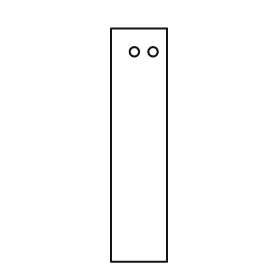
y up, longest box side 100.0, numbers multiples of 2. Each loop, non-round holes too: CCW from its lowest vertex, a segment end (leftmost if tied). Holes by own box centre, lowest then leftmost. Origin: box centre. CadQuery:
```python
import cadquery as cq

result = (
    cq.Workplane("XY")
    .moveTo(-12.0, -50.0)
    .lineTo(12.0, -50.0)
    .lineTo(12.0, 50.0)
    .lineTo(-12.0, 50.0)
    .close()
    .moveTo(-2.0, 40.0)
    .circle(2.0)
    .moveTo(6.0, 40.0)
    .circle(2.0)
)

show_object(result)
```